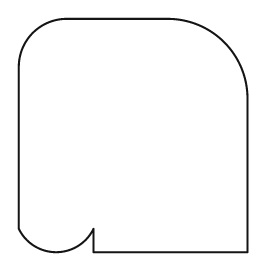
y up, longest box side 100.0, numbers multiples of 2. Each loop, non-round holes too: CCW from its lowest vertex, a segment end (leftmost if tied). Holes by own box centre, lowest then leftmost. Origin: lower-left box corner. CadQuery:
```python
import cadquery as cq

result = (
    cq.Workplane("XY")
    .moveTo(32.0, 0.0)
    .lineTo(98.0, 0.0)
    .lineTo(98.0, 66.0)
    .threePointArc((88.0, 90.0), (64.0, 100.0))
    .lineTo(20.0, 100.0)
    .threePointArc((6.0, 94.0), (0.0, 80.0))
    .lineTo(0.0, 10.0)
    .threePointArc((16.0, 0.0), (32.0, 10.0))
    .close()
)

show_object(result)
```